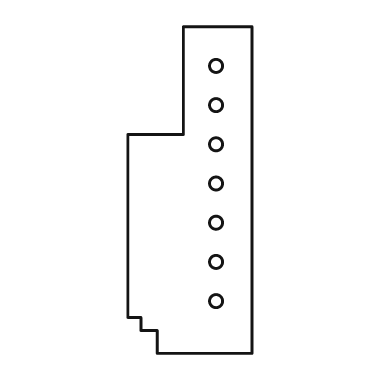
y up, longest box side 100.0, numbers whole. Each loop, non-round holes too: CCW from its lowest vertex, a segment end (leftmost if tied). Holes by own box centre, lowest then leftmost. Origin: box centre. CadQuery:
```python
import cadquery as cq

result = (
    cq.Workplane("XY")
    .moveTo(-10.0, -50.0)
    .lineTo(19.0, -50.0)
    .lineTo(19.0, 50.0)
    .lineTo(-2.0, 50.0)
    .lineTo(-2.0, 17.0)
    .lineTo(-19.0, 17.0)
    .lineTo(-19.0, -39.0)
    .lineTo(-15.0, -39.0)
    .lineTo(-15.0, -43.0)
    .lineTo(-10.0, -43.0)
    .close()
    .moveTo(8.0, -34.0)
    .circle(2.0)
    .moveTo(8.0, -22.0)
    .circle(2.0)
    .moveTo(8.0, -10.0)
    .circle(2.0)
    .moveTo(8.0, 2.0)
    .circle(2.0)
    .moveTo(8.0, 14.0)
    .circle(2.0)
    .moveTo(8.0, 26.0)
    .circle(2.0)
    .moveTo(8.0, 38.0)
    .circle(2.0)
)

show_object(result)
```